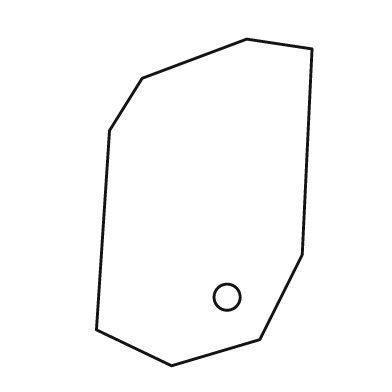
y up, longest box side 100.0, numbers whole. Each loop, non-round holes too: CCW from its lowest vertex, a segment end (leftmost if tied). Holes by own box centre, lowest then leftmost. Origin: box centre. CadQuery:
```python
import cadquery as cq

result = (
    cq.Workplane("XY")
    .moveTo(-10.0, -50.0)
    .lineTo(17.0, -42.0)
    .lineTo(30.0, -16.0)
    .lineTo(33.0, 47.0)
    .lineTo(13.0, 50.0)
    .lineTo(-19.0, 38.0)
    .lineTo(-29.0, 22.0)
    .lineTo(-33.0, -39.0)
    .close()
    .moveTo(7.0, -29.0)
    .circle(4.0)
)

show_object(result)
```